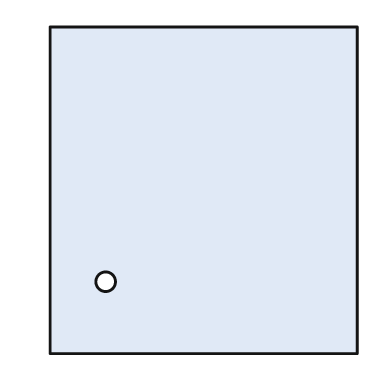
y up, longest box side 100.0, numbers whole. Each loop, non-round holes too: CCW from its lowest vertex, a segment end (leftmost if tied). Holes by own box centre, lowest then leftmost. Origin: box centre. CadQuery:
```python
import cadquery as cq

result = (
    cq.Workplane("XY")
    .moveTo(-47.0, -50.0)
    .lineTo(47.0, -50.0)
    .lineTo(47.0, 50.0)
    .lineTo(-47.0, 50.0)
    .close()
    .moveTo(-30.0, -28.0)
    .circle(3.0)
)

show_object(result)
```